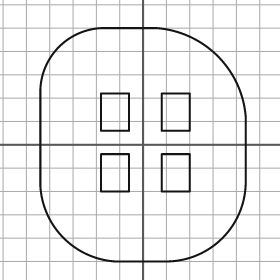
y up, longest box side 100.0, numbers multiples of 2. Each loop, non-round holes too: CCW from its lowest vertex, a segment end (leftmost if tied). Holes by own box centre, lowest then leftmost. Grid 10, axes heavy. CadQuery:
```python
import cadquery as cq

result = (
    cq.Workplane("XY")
    .moveTo(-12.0, -50.0)
    .lineTo(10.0, -50.0)
    .threePointArc((34.0, -40.0), (44.0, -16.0))
    .lineTo(44.0, 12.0)
    .threePointArc((32.0, 38.0), (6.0, 50.0))
    .lineTo(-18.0, 50.0)
    .threePointArc((-36.0, 42.0), (-44.0, 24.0))
    .lineTo(-44.0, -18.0)
    .threePointArc((-34.0, -40.0), (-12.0, -50.0))
    .close()
    .moveTo(-18.0, -20.0)
    .lineTo(-6.0, -20.0)
    .lineTo(-6.0, -4.0)
    .lineTo(-18.0, -4.0)
    .close()
    .moveTo(8.0, -20.0)
    .lineTo(20.0, -20.0)
    .lineTo(20.0, -4.0)
    .lineTo(8.0, -4.0)
    .close()
    .moveTo(-18.0, 6.0)
    .lineTo(-6.0, 6.0)
    .lineTo(-6.0, 22.0)
    .lineTo(-18.0, 22.0)
    .close()
    .moveTo(8.0, 6.0)
    .lineTo(20.0, 6.0)
    .lineTo(20.0, 22.0)
    .lineTo(8.0, 22.0)
    .close()
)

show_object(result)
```